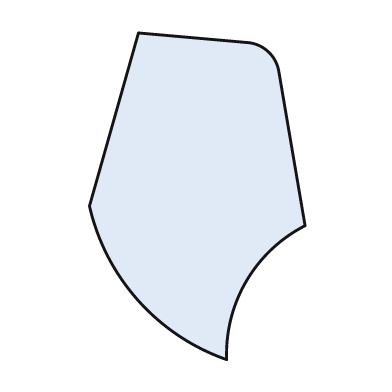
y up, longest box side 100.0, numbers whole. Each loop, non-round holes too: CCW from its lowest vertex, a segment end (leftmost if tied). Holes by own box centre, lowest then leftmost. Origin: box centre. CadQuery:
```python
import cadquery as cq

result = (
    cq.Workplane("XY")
    .moveTo(9.0, -50.0)
    .threePointArc((15.0, -26.0), (33.0, -9.0))
    .lineTo(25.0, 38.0)
    .threePointArc((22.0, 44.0), (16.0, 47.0))
    .lineTo(-18.0, 50.0)
    .lineTo(-33.0, -3.0)
    .threePointArc((-18.0, -32.0), (9.0, -50.0))
    .close()
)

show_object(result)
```